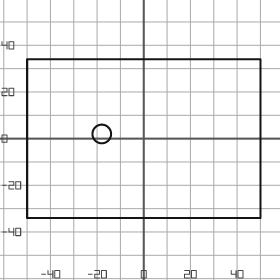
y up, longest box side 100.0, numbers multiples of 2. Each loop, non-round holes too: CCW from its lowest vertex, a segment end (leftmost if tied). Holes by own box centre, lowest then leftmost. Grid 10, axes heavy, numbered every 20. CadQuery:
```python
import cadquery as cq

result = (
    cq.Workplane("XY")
    .moveTo(-50.0, -34.0)
    .lineTo(50.0, -34.0)
    .lineTo(50.0, 34.0)
    .lineTo(-50.0, 34.0)
    .close()
    .moveTo(-18.0, 2.0)
    .circle(4.0)
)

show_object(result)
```